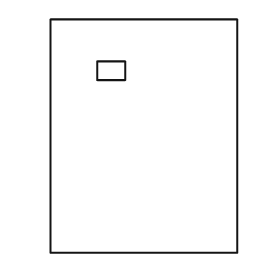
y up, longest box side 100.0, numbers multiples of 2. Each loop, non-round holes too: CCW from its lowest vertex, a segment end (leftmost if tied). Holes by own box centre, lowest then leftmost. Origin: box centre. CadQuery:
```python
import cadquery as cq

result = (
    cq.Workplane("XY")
    .moveTo(-40.0, -50.0)
    .lineTo(40.0, -50.0)
    .lineTo(40.0, 50.0)
    .lineTo(-40.0, 50.0)
    .close()
    .moveTo(-20.0, 24.0)
    .lineTo(-8.0, 24.0)
    .lineTo(-8.0, 32.0)
    .lineTo(-20.0, 32.0)
    .close()
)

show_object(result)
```